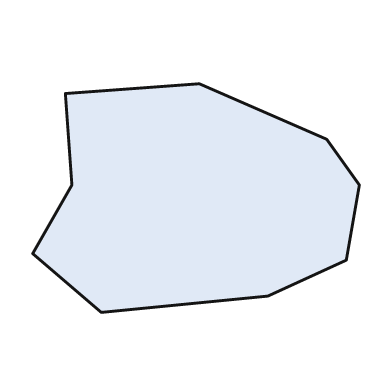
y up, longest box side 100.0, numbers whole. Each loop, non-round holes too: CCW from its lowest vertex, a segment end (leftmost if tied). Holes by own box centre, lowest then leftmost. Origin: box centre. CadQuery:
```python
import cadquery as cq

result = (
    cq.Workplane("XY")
    .moveTo(-29.0, -35.0)
    .lineTo(22.0, -30.0)
    .lineTo(46.0, -19.0)
    .lineTo(50.0, 4.0)
    .lineTo(40.0, 18.0)
    .lineTo(1.0, 35.0)
    .lineTo(-40.0, 32.0)
    .lineTo(-38.0, 4.0)
    .lineTo(-50.0, -17.0)
    .close()
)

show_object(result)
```